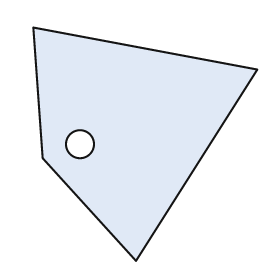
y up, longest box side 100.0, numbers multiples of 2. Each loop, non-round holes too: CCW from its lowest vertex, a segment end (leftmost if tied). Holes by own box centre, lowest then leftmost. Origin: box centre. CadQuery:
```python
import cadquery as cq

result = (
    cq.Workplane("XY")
    .moveTo(-4.0, -50.0)
    .lineTo(48.0, 32.0)
    .lineTo(-48.0, 50.0)
    .lineTo(-44.0, -6.0)
    .close()
    .moveTo(-28.0, 0.0)
    .circle(6.0)
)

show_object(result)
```